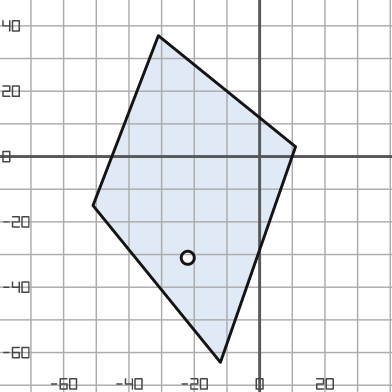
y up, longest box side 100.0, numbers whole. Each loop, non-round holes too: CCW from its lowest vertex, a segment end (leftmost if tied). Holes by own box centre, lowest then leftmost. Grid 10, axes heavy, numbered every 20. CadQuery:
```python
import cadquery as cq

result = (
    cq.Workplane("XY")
    .moveTo(-12.0, -63.0)
    .lineTo(11.0, 3.0)
    .lineTo(-31.0, 37.0)
    .lineTo(-51.0, -15.0)
    .close()
    .moveTo(-22.0, -31.0)
    .circle(2.0)
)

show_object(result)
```